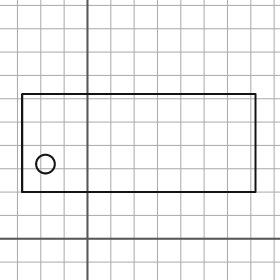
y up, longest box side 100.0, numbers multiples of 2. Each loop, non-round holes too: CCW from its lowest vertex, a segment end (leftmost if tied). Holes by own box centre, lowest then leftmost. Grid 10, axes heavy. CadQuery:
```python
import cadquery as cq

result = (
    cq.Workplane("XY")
    .moveTo(-28.0, 20.0)
    .lineTo(72.0, 20.0)
    .lineTo(72.0, 62.0)
    .lineTo(-28.0, 62.0)
    .close()
    .moveTo(-18.0, 32.0)
    .circle(4.0)
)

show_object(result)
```